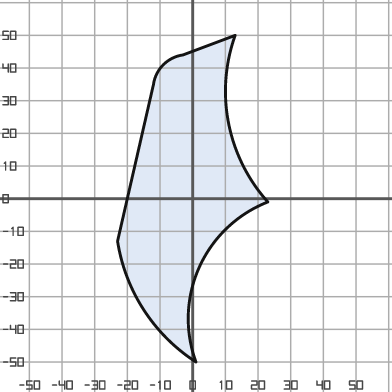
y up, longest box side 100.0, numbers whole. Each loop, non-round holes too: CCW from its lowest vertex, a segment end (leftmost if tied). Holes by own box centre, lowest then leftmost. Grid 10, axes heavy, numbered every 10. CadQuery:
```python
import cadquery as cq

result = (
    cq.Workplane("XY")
    .moveTo(1.0, -50.0)
    .threePointArc((2.0, -21.0), (23.0, -1.0))
    .threePointArc((11.0, 23.0), (13.0, 50.0))
    .lineTo(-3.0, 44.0)
    .threePointArc((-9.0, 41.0), (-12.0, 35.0))
    .lineTo(-23.0, -13.0)
    .threePointArc((-15.0, -34.0), (1.0, -50.0))
    .close()
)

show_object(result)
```